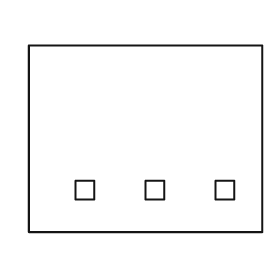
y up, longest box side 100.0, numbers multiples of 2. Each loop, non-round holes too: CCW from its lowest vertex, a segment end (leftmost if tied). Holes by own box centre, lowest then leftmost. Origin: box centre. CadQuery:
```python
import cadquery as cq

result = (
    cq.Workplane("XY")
    .moveTo(-50.0, -40.0)
    .lineTo(50.0, -40.0)
    .lineTo(50.0, 40.0)
    .lineTo(-50.0, 40.0)
    .close()
    .moveTo(-30.0, -26.0)
    .lineTo(-22.0, -26.0)
    .lineTo(-22.0, -18.0)
    .lineTo(-30.0, -18.0)
    .close()
    .moveTo(0.0, -26.0)
    .lineTo(8.0, -26.0)
    .lineTo(8.0, -18.0)
    .lineTo(0.0, -18.0)
    .close()
    .moveTo(30.0, -26.0)
    .lineTo(38.0, -26.0)
    .lineTo(38.0, -18.0)
    .lineTo(30.0, -18.0)
    .close()
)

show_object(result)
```